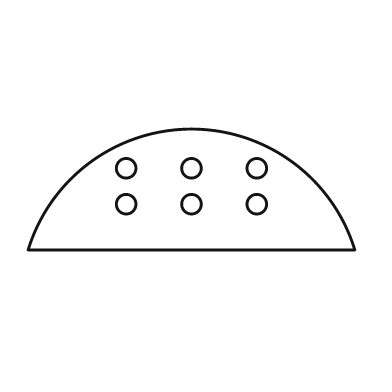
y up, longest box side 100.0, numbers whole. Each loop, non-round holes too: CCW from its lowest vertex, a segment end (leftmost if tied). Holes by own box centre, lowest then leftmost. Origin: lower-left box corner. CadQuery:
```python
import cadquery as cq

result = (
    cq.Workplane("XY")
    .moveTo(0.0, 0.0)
    .lineTo(100.0, 0.0)
    .threePointArc((50.0, 37.0), (0.0, 0.0))
    .close()
    .moveTo(30.0, 14.0)
    .circle(3.0)
    .moveTo(50.0, 14.0)
    .circle(3.0)
    .moveTo(70.0, 14.0)
    .circle(3.0)
    .moveTo(30.0, 25.0)
    .circle(3.0)
    .moveTo(50.0, 25.0)
    .circle(3.0)
    .moveTo(70.0, 25.0)
    .circle(3.0)
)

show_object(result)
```